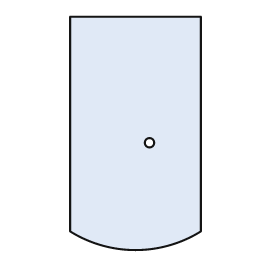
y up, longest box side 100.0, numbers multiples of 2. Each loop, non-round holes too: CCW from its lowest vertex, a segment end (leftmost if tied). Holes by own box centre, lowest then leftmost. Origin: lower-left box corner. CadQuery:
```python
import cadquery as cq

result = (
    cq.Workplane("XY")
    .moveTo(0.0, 8.0)
    .threePointArc((28.0, 0.0), (56.0, 8.0))
    .lineTo(56.0, 100.0)
    .lineTo(0.0, 100.0)
    .close()
    .moveTo(34.0, 46.0)
    .circle(2.0)
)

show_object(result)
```